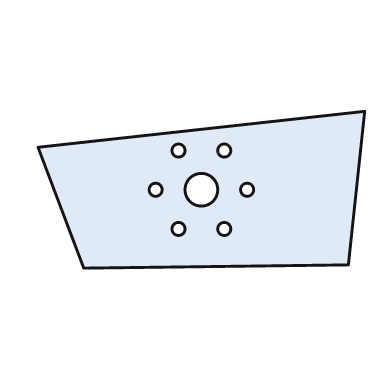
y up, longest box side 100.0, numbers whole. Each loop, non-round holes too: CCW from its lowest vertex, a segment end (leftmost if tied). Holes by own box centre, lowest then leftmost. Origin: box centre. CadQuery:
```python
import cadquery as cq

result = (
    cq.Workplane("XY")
    .moveTo(-36.0, -24.0)
    .lineTo(45.0, -23.0)
    .lineTo(50.0, 24.0)
    .lineTo(-50.0, 13.0)
    .close()
    .moveTo(-7.0, -12.0)
    .circle(2.0)
    .moveTo(7.0, -12.0)
    .circle(2.0)
    .moveTo(-14.0, 0.0)
    .circle(2.0)
    .moveTo(0.0, 0.0)
    .circle(5.0)
    .moveTo(14.0, 0.0)
    .circle(2.0)
    .moveTo(-7.0, 12.0)
    .circle(2.0)
    .moveTo(7.0, 12.0)
    .circle(2.0)
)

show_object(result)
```